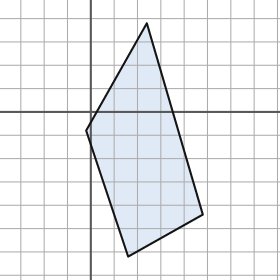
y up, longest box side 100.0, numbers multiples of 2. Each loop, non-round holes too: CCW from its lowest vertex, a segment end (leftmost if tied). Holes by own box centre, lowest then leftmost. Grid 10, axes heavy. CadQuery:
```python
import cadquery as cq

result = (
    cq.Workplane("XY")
    .moveTo(16.0, -62.0)
    .lineTo(48.0, -44.0)
    .lineTo(24.0, 38.0)
    .lineTo(-2.0, -8.0)
    .close()
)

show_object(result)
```